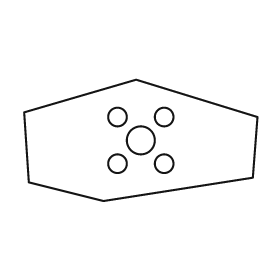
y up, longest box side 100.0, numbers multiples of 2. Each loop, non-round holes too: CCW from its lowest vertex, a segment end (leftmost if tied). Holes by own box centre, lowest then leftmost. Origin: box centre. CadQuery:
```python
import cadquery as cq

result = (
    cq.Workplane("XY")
    .moveTo(-16.0, -26.0)
    .lineTo(48.0, -16.0)
    .lineTo(50.0, 10.0)
    .lineTo(-2.0, 26.0)
    .lineTo(-50.0, 12.0)
    .lineTo(-48.0, -18.0)
    .close()
    .moveTo(-10.0, -10.0)
    .circle(4.0)
    .moveTo(10.0, -10.0)
    .circle(4.0)
    .moveTo(0.0, 0.0)
    .circle(6.0)
    .moveTo(-10.0, 10.0)
    .circle(4.0)
    .moveTo(10.0, 10.0)
    .circle(4.0)
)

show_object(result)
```